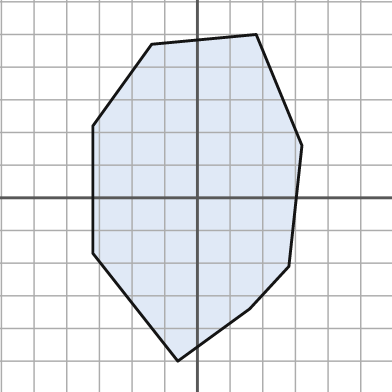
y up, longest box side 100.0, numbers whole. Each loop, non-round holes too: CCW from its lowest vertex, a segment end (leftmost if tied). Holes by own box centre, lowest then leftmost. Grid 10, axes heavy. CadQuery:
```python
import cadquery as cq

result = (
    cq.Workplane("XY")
    .moveTo(-6.0, -50.0)
    .lineTo(16.0, -34.0)
    .lineTo(28.0, -21.0)
    .lineTo(32.0, 16.0)
    .lineTo(18.0, 50.0)
    .lineTo(-14.0, 47.0)
    .lineTo(-32.0, 22.0)
    .lineTo(-32.0, -17.0)
    .close()
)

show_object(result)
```